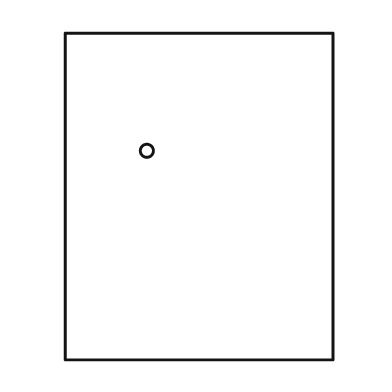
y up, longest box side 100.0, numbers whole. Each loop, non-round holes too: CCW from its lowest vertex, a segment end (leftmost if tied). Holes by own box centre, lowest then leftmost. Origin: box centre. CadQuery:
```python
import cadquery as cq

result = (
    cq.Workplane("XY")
    .moveTo(-41.0, -50.0)
    .lineTo(41.0, -50.0)
    .lineTo(41.0, 50.0)
    .lineTo(-41.0, 50.0)
    .close()
    .moveTo(-16.0, 14.0)
    .circle(2.0)
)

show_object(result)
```